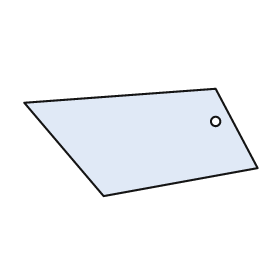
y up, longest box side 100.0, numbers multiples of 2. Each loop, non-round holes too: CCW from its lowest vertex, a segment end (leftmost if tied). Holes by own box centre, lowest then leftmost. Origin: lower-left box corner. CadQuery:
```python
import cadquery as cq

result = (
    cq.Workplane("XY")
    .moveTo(34.0, 0.0)
    .lineTo(100.0, 12.0)
    .lineTo(82.0, 46.0)
    .lineTo(0.0, 40.0)
    .close()
    .moveTo(82.0, 32.0)
    .circle(2.0)
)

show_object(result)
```